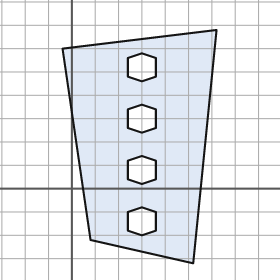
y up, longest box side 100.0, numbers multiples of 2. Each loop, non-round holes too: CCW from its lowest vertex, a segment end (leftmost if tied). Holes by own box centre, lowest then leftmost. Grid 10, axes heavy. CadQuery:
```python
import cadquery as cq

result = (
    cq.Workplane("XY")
    .moveTo(52.0, -32.0)
    .lineTo(62.0, 68.0)
    .lineTo(-4.0, 60.0)
    .lineTo(8.0, -22.0)
    .close()
    .moveTo(30.0, -20.0)
    .lineTo(36.0, -18.0)
    .lineTo(36.0, -10.0)
    .lineTo(30.0, -8.0)
    .lineTo(24.0, -10.0)
    .lineTo(24.0, -18.0)
    .close()
    .moveTo(30.0, 2.0)
    .lineTo(36.0, 4.0)
    .lineTo(36.0, 12.0)
    .lineTo(30.0, 14.0)
    .lineTo(24.0, 12.0)
    .lineTo(24.0, 4.0)
    .close()
    .moveTo(30.0, 24.0)
    .lineTo(36.0, 26.0)
    .lineTo(36.0, 34.0)
    .lineTo(30.0, 36.0)
    .lineTo(24.0, 34.0)
    .lineTo(24.0, 26.0)
    .close()
    .moveTo(30.0, 46.0)
    .lineTo(36.0, 48.0)
    .lineTo(36.0, 56.0)
    .lineTo(30.0, 58.0)
    .lineTo(24.0, 56.0)
    .lineTo(24.0, 48.0)
    .close()
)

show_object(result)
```